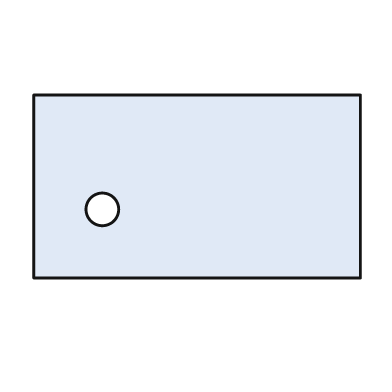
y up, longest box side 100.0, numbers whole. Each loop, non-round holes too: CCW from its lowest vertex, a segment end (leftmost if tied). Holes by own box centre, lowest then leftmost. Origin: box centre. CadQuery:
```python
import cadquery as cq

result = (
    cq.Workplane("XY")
    .moveTo(-50.0, -28.0)
    .lineTo(50.0, -28.0)
    .lineTo(50.0, 28.0)
    .lineTo(-50.0, 28.0)
    .close()
    .moveTo(-29.0, -7.0)
    .circle(5.0)
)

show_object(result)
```